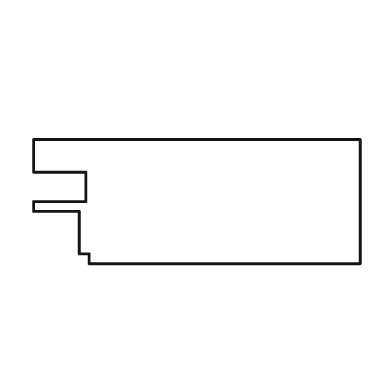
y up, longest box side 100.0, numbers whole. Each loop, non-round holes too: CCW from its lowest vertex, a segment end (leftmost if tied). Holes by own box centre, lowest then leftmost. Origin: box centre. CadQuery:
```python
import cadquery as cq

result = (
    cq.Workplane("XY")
    .moveTo(-33.0, -19.0)
    .lineTo(50.0, -19.0)
    .lineTo(50.0, 19.0)
    .lineTo(-50.0, 19.0)
    .lineTo(-50.0, 9.0)
    .lineTo(-34.0, 9.0)
    .lineTo(-34.0, 0.0)
    .lineTo(-50.0, 0.0)
    .lineTo(-50.0, -3.0)
    .lineTo(-36.0, -3.0)
    .lineTo(-36.0, -16.0)
    .lineTo(-33.0, -16.0)
    .close()
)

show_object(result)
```